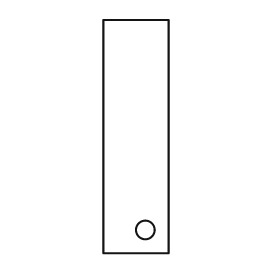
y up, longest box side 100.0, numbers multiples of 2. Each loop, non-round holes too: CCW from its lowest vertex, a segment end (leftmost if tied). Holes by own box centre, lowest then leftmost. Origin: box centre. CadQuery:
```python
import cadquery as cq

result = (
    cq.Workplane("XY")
    .moveTo(-14.0, -50.0)
    .lineTo(14.0, -50.0)
    .lineTo(14.0, 50.0)
    .lineTo(-14.0, 50.0)
    .close()
    .moveTo(4.0, -40.0)
    .circle(4.0)
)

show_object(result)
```